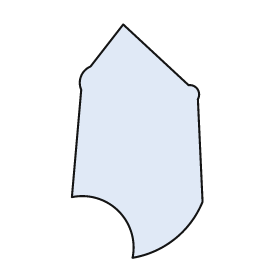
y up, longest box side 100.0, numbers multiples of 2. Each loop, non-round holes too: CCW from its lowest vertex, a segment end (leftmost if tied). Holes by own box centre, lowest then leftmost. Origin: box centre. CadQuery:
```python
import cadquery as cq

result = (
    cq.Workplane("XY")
    .moveTo(-2.0, -50.0)
    .threePointArc((16.0, -42.0), (28.0, -26.0))
    .lineTo(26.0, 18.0)
    .threePointArc((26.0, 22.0), (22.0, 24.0))
    .lineTo(-6.0, 50.0)
    .lineTo(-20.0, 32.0)
    .threePointArc((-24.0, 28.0), (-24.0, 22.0))
    .lineTo(-28.0, -24.0)
    .threePointArc((-8.0, -30.0), (-2.0, -50.0))
    .close()
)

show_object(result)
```